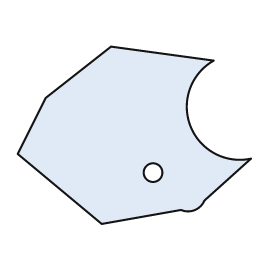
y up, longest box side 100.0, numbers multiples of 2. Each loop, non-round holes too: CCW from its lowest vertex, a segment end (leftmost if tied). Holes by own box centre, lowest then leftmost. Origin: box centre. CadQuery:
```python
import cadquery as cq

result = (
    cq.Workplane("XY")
    .moveTo(-14.0, -38.0)
    .lineTo(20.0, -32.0)
    .threePointArc((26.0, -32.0), (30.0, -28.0))
    .lineTo(50.0, -10.0)
    .threePointArc((24.0, 4.0), (34.0, 32.0))
    .lineTo(-10.0, 38.0)
    .lineTo(-38.0, 16.0)
    .lineTo(-50.0, -8.0)
    .close()
    .moveTo(8.0, -16.0)
    .circle(4.0)
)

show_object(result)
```